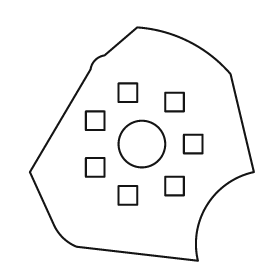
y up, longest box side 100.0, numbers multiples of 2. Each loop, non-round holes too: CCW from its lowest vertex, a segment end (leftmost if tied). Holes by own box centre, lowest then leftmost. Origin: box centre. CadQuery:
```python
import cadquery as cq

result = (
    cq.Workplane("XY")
    .moveTo(24.0, -50.0)
    .threePointArc((28.0, -26.0), (48.0, -12.0))
    .lineTo(38.0, 30.0)
    .threePointArc((20.0, 44.0), (-2.0, 50.0))
    .lineTo(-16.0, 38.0)
    .threePointArc((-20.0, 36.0), (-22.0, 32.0))
    .lineTo(-48.0, -12.0)
    .lineTo(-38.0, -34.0)
    .threePointArc((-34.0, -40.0), (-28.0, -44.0))
    .close()
    .moveTo(-10.0, -26.0)
    .lineTo(-2.0, -26.0)
    .lineTo(-2.0, -18.0)
    .lineTo(-10.0, -18.0)
    .close()
    .moveTo(10.0, -22.0)
    .lineTo(18.0, -22.0)
    .lineTo(18.0, -14.0)
    .lineTo(10.0, -14.0)
    .close()
    .moveTo(-24.0, -14.0)
    .lineTo(-16.0, -14.0)
    .lineTo(-16.0, -6.0)
    .lineTo(-24.0, -6.0)
    .close()
    .moveTo(0.0, 0.0)
    .circle(10.0)
    .moveTo(18.0, -4.0)
    .lineTo(26.0, -4.0)
    .lineTo(26.0, 4.0)
    .lineTo(18.0, 4.0)
    .close()
    .moveTo(-24.0, 6.0)
    .lineTo(-16.0, 6.0)
    .lineTo(-16.0, 14.0)
    .lineTo(-24.0, 14.0)
    .close()
    .moveTo(10.0, 14.0)
    .lineTo(18.0, 14.0)
    .lineTo(18.0, 22.0)
    .lineTo(10.0, 22.0)
    .close()
    .moveTo(-10.0, 18.0)
    .lineTo(-2.0, 18.0)
    .lineTo(-2.0, 26.0)
    .lineTo(-10.0, 26.0)
    .close()
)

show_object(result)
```